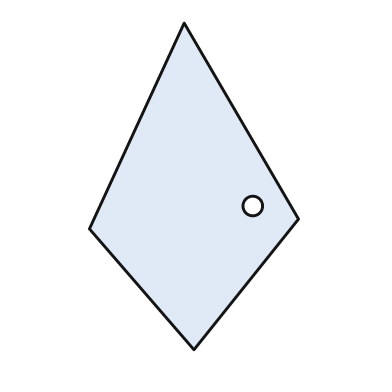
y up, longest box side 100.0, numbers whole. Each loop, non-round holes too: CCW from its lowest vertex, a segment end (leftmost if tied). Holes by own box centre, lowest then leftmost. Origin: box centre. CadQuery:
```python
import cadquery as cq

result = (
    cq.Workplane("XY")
    .moveTo(0.0, -50.0)
    .lineTo(32.0, -10.0)
    .lineTo(-3.0, 50.0)
    .lineTo(-32.0, -13.0)
    .close()
    .moveTo(18.0, -6.0)
    .circle(3.0)
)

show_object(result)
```